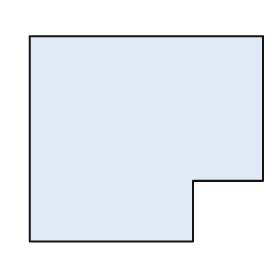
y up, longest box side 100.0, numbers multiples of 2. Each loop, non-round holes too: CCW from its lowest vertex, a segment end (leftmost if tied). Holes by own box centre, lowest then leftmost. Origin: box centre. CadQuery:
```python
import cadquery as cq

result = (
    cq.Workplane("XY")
    .moveTo(-50.0, -44.0)
    .lineTo(20.0, -44.0)
    .lineTo(20.0, -18.0)
    .lineTo(50.0, -18.0)
    .lineTo(50.0, 44.0)
    .lineTo(-50.0, 44.0)
    .close()
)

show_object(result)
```